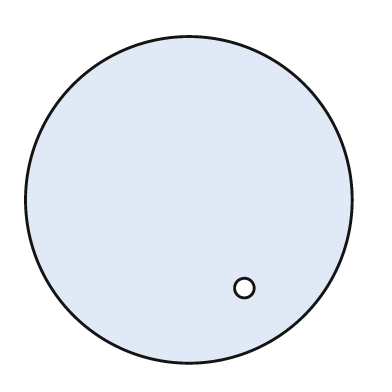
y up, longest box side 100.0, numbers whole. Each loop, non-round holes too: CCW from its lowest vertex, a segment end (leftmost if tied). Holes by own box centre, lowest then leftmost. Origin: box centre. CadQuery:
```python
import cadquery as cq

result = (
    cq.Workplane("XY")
    .moveTo(0.0, 0.0)
    .circle(50.0)
    .moveTo(17.0, -27.0)
    .circle(3.0)
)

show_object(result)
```